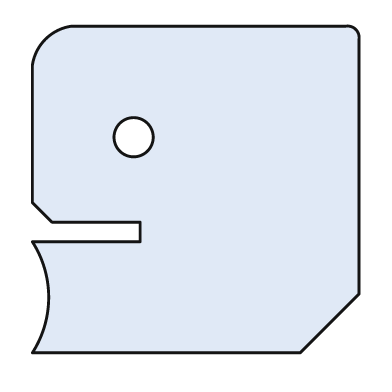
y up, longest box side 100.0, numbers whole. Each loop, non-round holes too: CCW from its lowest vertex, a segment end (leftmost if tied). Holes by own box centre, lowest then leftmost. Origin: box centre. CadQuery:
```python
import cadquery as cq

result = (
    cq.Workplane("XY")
    .moveTo(-50.0, -50.0)
    .lineTo(32.0, -50.0)
    .lineTo(50.0, -32.0)
    .lineTo(50.0, 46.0)
    .threePointArc((49.0, 49.0), (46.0, 50.0))
    .lineTo(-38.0, 50.0)
    .threePointArc((-46.0, 46.0), (-50.0, 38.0))
    .lineTo(-50.0, -4.0)
    .lineTo(-44.0, -10.0)
    .lineTo(-17.0, -10.0)
    .lineTo(-17.0, -16.0)
    .lineTo(-50.0, -16.0)
    .threePointArc((-45.0, -33.0), (-50.0, -50.0))
    .close()
    .moveTo(-19.0, 16.0)
    .circle(6.0)
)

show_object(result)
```